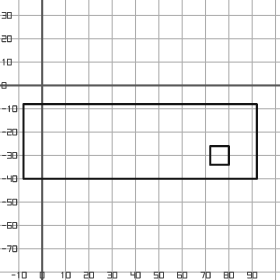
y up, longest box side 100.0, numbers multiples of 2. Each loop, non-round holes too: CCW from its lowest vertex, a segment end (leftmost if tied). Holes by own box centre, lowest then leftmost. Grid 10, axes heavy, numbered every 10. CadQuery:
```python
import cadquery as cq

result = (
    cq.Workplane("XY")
    .moveTo(-8.0, -40.0)
    .lineTo(92.0, -40.0)
    .lineTo(92.0, -8.0)
    .lineTo(-8.0, -8.0)
    .close()
    .moveTo(72.0, -34.0)
    .lineTo(80.0, -34.0)
    .lineTo(80.0, -26.0)
    .lineTo(72.0, -26.0)
    .close()
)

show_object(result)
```